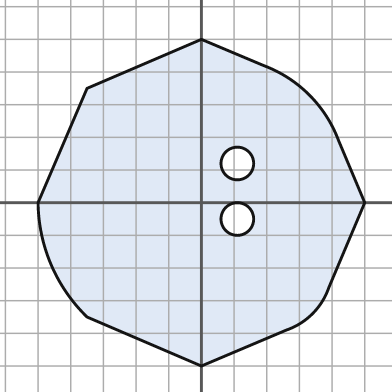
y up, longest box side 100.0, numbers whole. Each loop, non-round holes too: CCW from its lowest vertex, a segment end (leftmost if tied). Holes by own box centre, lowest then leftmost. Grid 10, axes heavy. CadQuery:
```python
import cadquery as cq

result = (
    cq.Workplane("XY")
    .moveTo(0.0, -50.0)
    .lineTo(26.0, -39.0)
    .threePointArc((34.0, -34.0), (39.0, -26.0))
    .lineTo(50.0, 0.0)
    .lineTo(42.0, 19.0)
    .threePointArc((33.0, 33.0), (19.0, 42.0))
    .lineTo(0.0, 50.0)
    .lineTo(-35.0, 35.0)
    .lineTo(-50.0, 0.0)
    .threePointArc((-46.0, -19.0), (-35.0, -35.0))
    .close()
    .moveTo(11.0, -5.0)
    .circle(5.0)
    .moveTo(11.0, 12.0)
    .circle(5.0)
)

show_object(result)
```